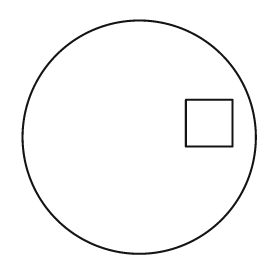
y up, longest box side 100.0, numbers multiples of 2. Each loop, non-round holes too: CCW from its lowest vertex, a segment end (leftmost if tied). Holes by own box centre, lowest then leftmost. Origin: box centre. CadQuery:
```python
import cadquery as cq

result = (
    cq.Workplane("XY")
    .moveTo(0.0, 0.0)
    .circle(50.0)
    .moveTo(20.0, -4.0)
    .lineTo(40.0, -4.0)
    .lineTo(40.0, 16.0)
    .lineTo(20.0, 16.0)
    .close()
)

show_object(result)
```